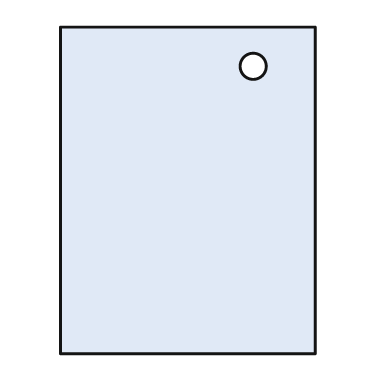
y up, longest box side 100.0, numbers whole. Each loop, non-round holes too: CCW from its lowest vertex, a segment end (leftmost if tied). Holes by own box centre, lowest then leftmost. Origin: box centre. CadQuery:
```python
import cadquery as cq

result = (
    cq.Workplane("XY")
    .moveTo(-39.0, -50.0)
    .lineTo(39.0, -50.0)
    .lineTo(39.0, 50.0)
    .lineTo(-39.0, 50.0)
    .close()
    .moveTo(20.0, 38.0)
    .circle(4.0)
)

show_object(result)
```